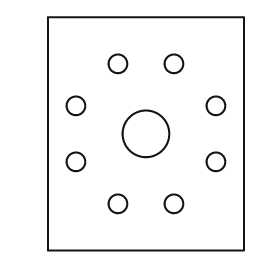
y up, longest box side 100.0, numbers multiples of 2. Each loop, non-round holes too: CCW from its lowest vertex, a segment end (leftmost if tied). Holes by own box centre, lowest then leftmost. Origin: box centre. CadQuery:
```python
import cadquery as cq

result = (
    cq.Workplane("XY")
    .moveTo(-42.0, -50.0)
    .lineTo(42.0, -50.0)
    .lineTo(42.0, 50.0)
    .lineTo(-42.0, 50.0)
    .close()
    .moveTo(-12.0, -30.0)
    .circle(4.0)
    .moveTo(12.0, -30.0)
    .circle(4.0)
    .moveTo(-30.0, -12.0)
    .circle(4.0)
    .moveTo(30.0, -12.0)
    .circle(4.0)
    .moveTo(0.0, 0.0)
    .circle(10.0)
    .moveTo(-30.0, 12.0)
    .circle(4.0)
    .moveTo(30.0, 12.0)
    .circle(4.0)
    .moveTo(-12.0, 30.0)
    .circle(4.0)
    .moveTo(12.0, 30.0)
    .circle(4.0)
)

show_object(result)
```